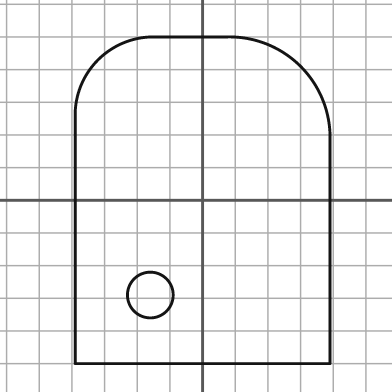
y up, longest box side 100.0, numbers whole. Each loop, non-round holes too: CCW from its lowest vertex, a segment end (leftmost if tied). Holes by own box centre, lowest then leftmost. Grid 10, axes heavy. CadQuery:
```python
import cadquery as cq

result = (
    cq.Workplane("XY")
    .moveTo(-39.0, -50.0)
    .lineTo(39.0, -50.0)
    .lineTo(39.0, 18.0)
    .threePointArc((30.0, 41.0), (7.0, 50.0))
    .lineTo(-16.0, 50.0)
    .threePointArc((-32.0, 43.0), (-39.0, 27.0))
    .close()
    .moveTo(-16.0, -29.0)
    .circle(7.0)
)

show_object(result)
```